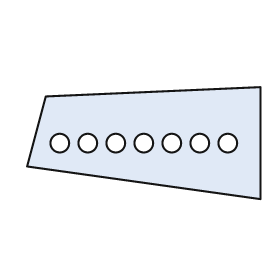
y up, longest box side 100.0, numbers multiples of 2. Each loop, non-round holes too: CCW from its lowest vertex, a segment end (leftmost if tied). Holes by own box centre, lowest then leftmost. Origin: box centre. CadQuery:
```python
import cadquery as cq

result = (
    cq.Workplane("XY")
    .moveTo(50.0, -24.0)
    .lineTo(50.0, 24.0)
    .lineTo(-42.0, 20.0)
    .lineTo(-50.0, -10.0)
    .close()
    .moveTo(-36.0, 0.0)
    .circle(4.0)
    .moveTo(-24.0, 0.0)
    .circle(4.0)
    .moveTo(-12.0, 0.0)
    .circle(4.0)
    .moveTo(0.0, 0.0)
    .circle(4.0)
    .moveTo(12.0, 0.0)
    .circle(4.0)
    .moveTo(24.0, 0.0)
    .circle(4.0)
    .moveTo(36.0, 0.0)
    .circle(4.0)
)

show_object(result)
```